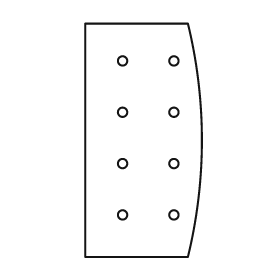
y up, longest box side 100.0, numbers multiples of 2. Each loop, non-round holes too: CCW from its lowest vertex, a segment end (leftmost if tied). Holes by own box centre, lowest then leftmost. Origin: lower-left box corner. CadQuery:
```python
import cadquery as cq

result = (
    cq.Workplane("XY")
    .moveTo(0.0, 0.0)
    .lineTo(44.0, 0.0)
    .threePointArc((50.0, 50.0), (44.0, 100.0))
    .lineTo(0.0, 100.0)
    .close()
    .moveTo(16.0, 18.0)
    .circle(2.0)
    .moveTo(38.0, 18.0)
    .circle(2.0)
    .moveTo(16.0, 40.0)
    .circle(2.0)
    .moveTo(38.0, 40.0)
    .circle(2.0)
    .moveTo(16.0, 62.0)
    .circle(2.0)
    .moveTo(38.0, 62.0)
    .circle(2.0)
    .moveTo(16.0, 84.0)
    .circle(2.0)
    .moveTo(38.0, 84.0)
    .circle(2.0)
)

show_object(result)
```